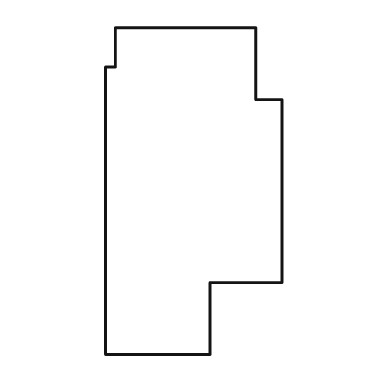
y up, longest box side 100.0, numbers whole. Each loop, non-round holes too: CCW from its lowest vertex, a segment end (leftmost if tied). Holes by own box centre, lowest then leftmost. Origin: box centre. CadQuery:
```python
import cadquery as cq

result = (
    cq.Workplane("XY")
    .moveTo(-27.0, -50.0)
    .lineTo(5.0, -50.0)
    .lineTo(5.0, -28.0)
    .lineTo(27.0, -28.0)
    .lineTo(27.0, 28.0)
    .lineTo(19.0, 28.0)
    .lineTo(19.0, 50.0)
    .lineTo(-24.0, 50.0)
    .lineTo(-24.0, 38.0)
    .lineTo(-27.0, 38.0)
    .close()
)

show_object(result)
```